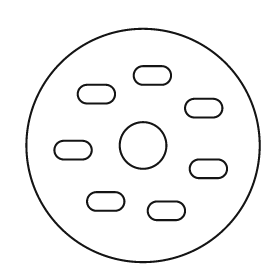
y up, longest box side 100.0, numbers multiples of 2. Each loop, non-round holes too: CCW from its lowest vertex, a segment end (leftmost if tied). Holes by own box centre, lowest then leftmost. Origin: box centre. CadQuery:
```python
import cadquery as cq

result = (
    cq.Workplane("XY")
    .moveTo(0.0, 0.0)
    .circle(50.0)
    .moveTo(6.0, -32.0)
    .lineTo(14.0, -32.0)
    .threePointArc((18.0, -28.0), (14.0, -24.0))
    .lineTo(6.0, -24.0)
    .threePointArc((2.0, -28.0), (6.0, -32.0))
    .close()
    .moveTo(-20.0, -28.0)
    .lineTo(-12.0, -28.0)
    .threePointArc((-8.0, -24.0), (-12.0, -20.0))
    .lineTo(-20.0, -20.0)
    .threePointArc((-24.0, -24.0), (-20.0, -28.0))
    .close()
    .moveTo(24.0, -14.0)
    .lineTo(32.0, -14.0)
    .threePointArc((36.0, -10.0), (32.0, -6.0))
    .lineTo(24.0, -6.0)
    .threePointArc((20.0, -10.0), (24.0, -14.0))
    .close()
    .moveTo(-34.0, -6.0)
    .lineTo(-26.0, -6.0)
    .threePointArc((-22.0, -2.0), (-26.0, 2.0))
    .lineTo(-34.0, 2.0)
    .threePointArc((-38.0, -2.0), (-34.0, -6.0))
    .close()
    .moveTo(0.0, 0.0)
    .circle(10.0)
    .moveTo(22.0, 12.0)
    .lineTo(30.0, 12.0)
    .threePointArc((34.0, 16.0), (30.0, 20.0))
    .lineTo(22.0, 20.0)
    .threePointArc((18.0, 16.0), (22.0, 12.0))
    .close()
    .moveTo(-24.0, 18.0)
    .lineTo(-16.0, 18.0)
    .threePointArc((-12.0, 22.0), (-16.0, 26.0))
    .lineTo(-24.0, 26.0)
    .threePointArc((-28.0, 22.0), (-24.0, 18.0))
    .close()
    .moveTo(0.0, 26.0)
    .lineTo(8.0, 26.0)
    .threePointArc((12.0, 30.0), (8.0, 34.0))
    .lineTo(0.0, 34.0)
    .threePointArc((-4.0, 30.0), (0.0, 26.0))
    .close()
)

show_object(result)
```